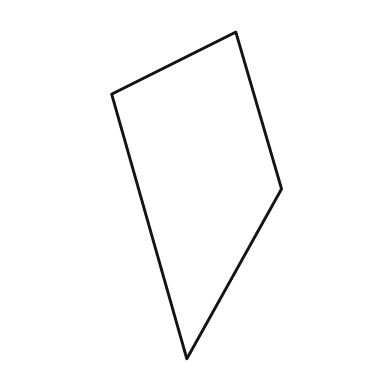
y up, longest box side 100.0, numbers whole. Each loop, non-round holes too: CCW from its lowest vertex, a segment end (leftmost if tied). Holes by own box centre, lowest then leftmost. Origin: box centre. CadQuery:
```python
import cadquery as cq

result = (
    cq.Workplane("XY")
    .moveTo(-3.0, -50.0)
    .lineTo(26.0, 2.0)
    .lineTo(12.0, 50.0)
    .lineTo(-26.0, 31.0)
    .close()
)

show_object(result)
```